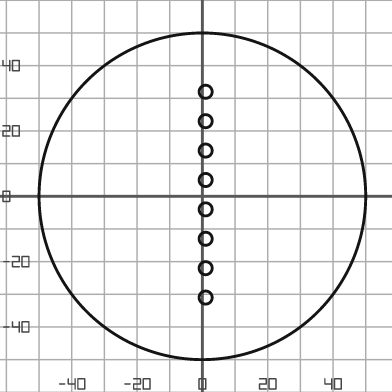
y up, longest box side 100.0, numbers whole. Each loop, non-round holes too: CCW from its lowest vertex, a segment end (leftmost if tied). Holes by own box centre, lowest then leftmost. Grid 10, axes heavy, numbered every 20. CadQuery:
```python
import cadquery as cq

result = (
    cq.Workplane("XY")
    .moveTo(0.0, 0.0)
    .circle(50.0)
    .moveTo(1.0, -31.0)
    .circle(2.0)
    .moveTo(1.0, -22.0)
    .circle(2.0)
    .moveTo(1.0, -13.0)
    .circle(2.0)
    .moveTo(1.0, -4.0)
    .circle(2.0)
    .moveTo(1.0, 5.0)
    .circle(2.0)
    .moveTo(1.0, 14.0)
    .circle(2.0)
    .moveTo(1.0, 23.0)
    .circle(2.0)
    .moveTo(1.0, 32.0)
    .circle(2.0)
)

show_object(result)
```